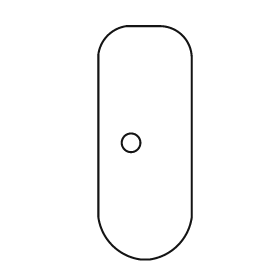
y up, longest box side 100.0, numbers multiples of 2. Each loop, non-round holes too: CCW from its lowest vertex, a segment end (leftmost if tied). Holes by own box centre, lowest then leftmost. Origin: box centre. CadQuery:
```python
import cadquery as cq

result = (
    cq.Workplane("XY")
    .moveTo(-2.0, -50.0)
    .lineTo(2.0, -50.0)
    .threePointArc((14.0, -44.0), (20.0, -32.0))
    .lineTo(20.0, 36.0)
    .threePointArc((16.0, 46.0), (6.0, 50.0))
    .lineTo(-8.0, 50.0)
    .threePointArc((-16.0, 46.0), (-20.0, 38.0))
    .lineTo(-20.0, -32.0)
    .threePointArc((-14.0, -44.0), (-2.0, -50.0))
    .close()
    .moveTo(-6.0, 0.0)
    .circle(4.0)
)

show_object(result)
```